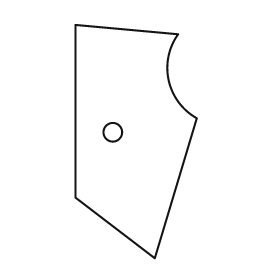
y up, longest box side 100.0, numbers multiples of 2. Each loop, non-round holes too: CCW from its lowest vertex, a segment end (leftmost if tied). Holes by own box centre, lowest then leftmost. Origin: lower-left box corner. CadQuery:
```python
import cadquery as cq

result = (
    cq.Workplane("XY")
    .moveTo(34.0, 0.0)
    .lineTo(52.0, 60.0)
    .threePointArc((40.0, 76.0), (44.0, 96.0))
    .lineTo(0.0, 100.0)
    .lineTo(0.0, 26.0)
    .close()
    .moveTo(16.0, 54.0)
    .circle(4.0)
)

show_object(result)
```